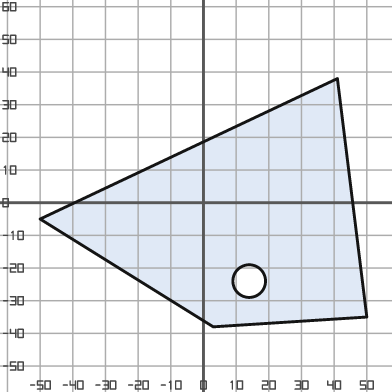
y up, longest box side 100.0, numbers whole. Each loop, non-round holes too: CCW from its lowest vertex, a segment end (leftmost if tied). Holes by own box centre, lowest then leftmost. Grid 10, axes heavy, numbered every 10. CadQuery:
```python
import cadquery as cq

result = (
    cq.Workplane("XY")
    .moveTo(3.0, -38.0)
    .lineTo(50.0, -35.0)
    .lineTo(41.0, 38.0)
    .lineTo(-50.0, -5.0)
    .close()
    .moveTo(14.0, -24.0)
    .circle(5.0)
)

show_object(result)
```